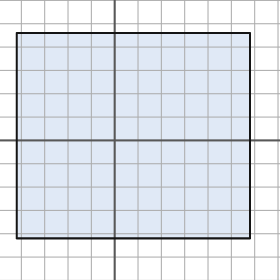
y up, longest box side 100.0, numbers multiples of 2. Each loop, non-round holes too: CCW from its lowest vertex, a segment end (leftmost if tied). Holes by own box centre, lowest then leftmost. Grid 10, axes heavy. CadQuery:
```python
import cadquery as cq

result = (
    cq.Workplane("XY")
    .moveTo(-42.0, -42.0)
    .lineTo(58.0, -42.0)
    .lineTo(58.0, 46.0)
    .lineTo(-42.0, 46.0)
    .close()
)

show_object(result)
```